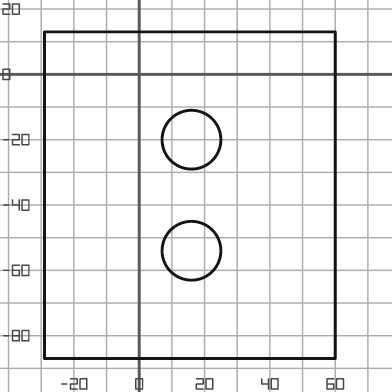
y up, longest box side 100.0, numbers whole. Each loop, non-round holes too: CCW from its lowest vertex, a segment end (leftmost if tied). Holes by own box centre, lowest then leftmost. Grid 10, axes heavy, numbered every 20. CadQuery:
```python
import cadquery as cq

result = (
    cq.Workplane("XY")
    .moveTo(-29.0, -87.0)
    .lineTo(60.0, -87.0)
    .lineTo(60.0, 13.0)
    .lineTo(-29.0, 13.0)
    .close()
    .moveTo(16.0, -54.0)
    .circle(9.0)
    .moveTo(16.0, -20.0)
    .circle(9.0)
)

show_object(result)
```